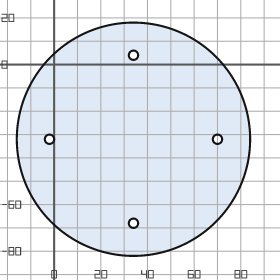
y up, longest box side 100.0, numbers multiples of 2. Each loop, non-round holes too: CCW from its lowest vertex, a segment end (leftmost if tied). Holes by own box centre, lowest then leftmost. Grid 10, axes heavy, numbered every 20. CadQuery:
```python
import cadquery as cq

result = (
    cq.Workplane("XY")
    .moveTo(34.0, -32.0)
    .circle(50.0)
    .moveTo(34.0, -68.0)
    .circle(2.0)
    .moveTo(-2.0, -32.0)
    .circle(2.0)
    .moveTo(70.0, -32.0)
    .circle(2.0)
    .moveTo(34.0, 4.0)
    .circle(2.0)
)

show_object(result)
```